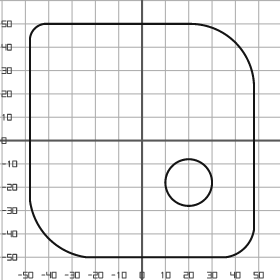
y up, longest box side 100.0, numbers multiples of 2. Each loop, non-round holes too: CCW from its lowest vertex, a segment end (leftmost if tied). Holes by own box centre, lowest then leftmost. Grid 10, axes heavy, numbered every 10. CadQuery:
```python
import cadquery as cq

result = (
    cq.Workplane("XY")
    .moveTo(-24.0, -50.0)
    .lineTo(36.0, -50.0)
    .threePointArc((44.0, -46.0), (48.0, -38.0))
    .lineTo(48.0, 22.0)
    .threePointArc((40.0, 42.0), (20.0, 50.0))
    .lineTo(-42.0, 50.0)
    .threePointArc((-46.0, 48.0), (-48.0, 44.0))
    .lineTo(-48.0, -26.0)
    .threePointArc((-40.0, -42.0), (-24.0, -50.0))
    .close()
    .moveTo(20.0, -18.0)
    .circle(10.0)
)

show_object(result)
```